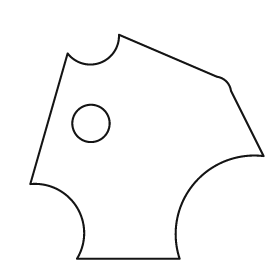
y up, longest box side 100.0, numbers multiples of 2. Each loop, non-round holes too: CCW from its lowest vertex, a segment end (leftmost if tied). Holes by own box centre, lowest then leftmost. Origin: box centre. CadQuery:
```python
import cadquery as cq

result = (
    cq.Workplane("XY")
    .moveTo(-30.0, -48.0)
    .lineTo(14.0, -48.0)
    .threePointArc((20.0, -16.0), (50.0, -4.0))
    .lineTo(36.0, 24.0)
    .threePointArc((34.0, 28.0), (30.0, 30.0))
    .lineTo(-12.0, 48.0)
    .threePointArc((-20.0, 36.0), (-34.0, 40.0))
    .lineTo(-50.0, -16.0)
    .threePointArc((-30.0, -26.0), (-30.0, -48.0))
    .close()
    .moveTo(-24.0, 10.0)
    .circle(8.0)
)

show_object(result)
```